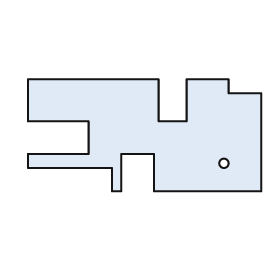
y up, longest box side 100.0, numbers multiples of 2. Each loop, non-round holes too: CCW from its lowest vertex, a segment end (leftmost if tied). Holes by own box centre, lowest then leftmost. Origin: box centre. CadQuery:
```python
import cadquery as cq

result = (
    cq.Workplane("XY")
    .moveTo(-14.0, -24.0)
    .lineTo(-10.0, -24.0)
    .lineTo(-10.0, -8.0)
    .lineTo(4.0, -8.0)
    .lineTo(4.0, -24.0)
    .lineTo(50.0, -24.0)
    .lineTo(50.0, 18.0)
    .lineTo(36.0, 18.0)
    .lineTo(36.0, 24.0)
    .lineTo(18.0, 24.0)
    .lineTo(18.0, 6.0)
    .lineTo(6.0, 6.0)
    .lineTo(6.0, 24.0)
    .lineTo(-50.0, 24.0)
    .lineTo(-50.0, 6.0)
    .lineTo(-24.0, 6.0)
    .lineTo(-24.0, -8.0)
    .lineTo(-50.0, -8.0)
    .lineTo(-50.0, -14.0)
    .lineTo(-14.0, -14.0)
    .close()
    .moveTo(34.0, -12.0)
    .circle(2.0)
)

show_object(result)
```